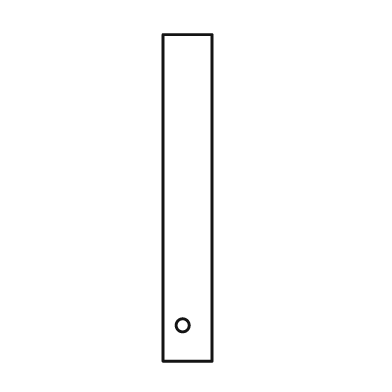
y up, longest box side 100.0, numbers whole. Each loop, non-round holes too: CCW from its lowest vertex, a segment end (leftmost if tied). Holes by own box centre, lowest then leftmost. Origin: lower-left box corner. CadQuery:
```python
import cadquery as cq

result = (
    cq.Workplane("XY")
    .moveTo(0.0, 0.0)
    .lineTo(15.0, 0.0)
    .lineTo(15.0, 100.0)
    .lineTo(0.0, 100.0)
    .close()
    .moveTo(6.0, 11.0)
    .circle(2.0)
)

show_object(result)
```